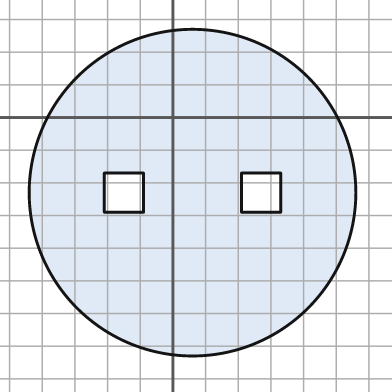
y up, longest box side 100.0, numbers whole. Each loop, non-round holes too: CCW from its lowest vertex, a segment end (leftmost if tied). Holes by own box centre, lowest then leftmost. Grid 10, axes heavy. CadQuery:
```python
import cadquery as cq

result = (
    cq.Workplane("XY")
    .moveTo(6.0, -23.0)
    .circle(50.0)
    .moveTo(-21.0, -29.0)
    .lineTo(-9.0, -29.0)
    .lineTo(-9.0, -17.0)
    .lineTo(-21.0, -17.0)
    .close()
    .moveTo(21.0, -29.0)
    .lineTo(33.0, -29.0)
    .lineTo(33.0, -17.0)
    .lineTo(21.0, -17.0)
    .close()
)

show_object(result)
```